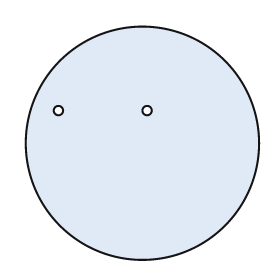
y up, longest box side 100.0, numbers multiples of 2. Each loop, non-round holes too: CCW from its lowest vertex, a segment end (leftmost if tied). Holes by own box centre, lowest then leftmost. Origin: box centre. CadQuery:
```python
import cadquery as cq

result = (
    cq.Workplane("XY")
    .moveTo(0.0, 0.0)
    .circle(50.0)
    .moveTo(-36.0, 14.0)
    .circle(2.0)
    .moveTo(2.0, 14.0)
    .circle(2.0)
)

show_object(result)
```